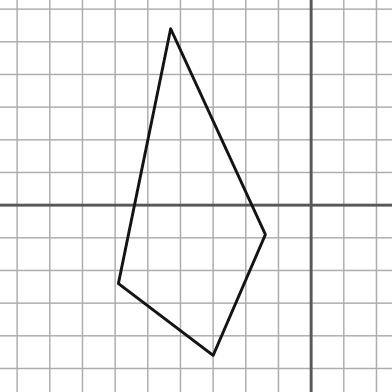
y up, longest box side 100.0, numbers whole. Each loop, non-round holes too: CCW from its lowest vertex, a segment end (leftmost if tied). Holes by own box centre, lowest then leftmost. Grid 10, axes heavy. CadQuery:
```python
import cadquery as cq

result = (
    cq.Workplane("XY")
    .moveTo(-30.0, -46.0)
    .lineTo(-14.0, -9.0)
    .lineTo(-43.0, 54.0)
    .lineTo(-59.0, -24.0)
    .close()
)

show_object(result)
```